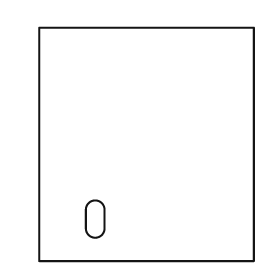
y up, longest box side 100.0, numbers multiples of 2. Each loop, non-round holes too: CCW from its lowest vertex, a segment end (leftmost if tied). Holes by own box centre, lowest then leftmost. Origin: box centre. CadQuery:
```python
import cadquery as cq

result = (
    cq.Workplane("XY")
    .moveTo(-46.0, -50.0)
    .lineTo(46.0, -50.0)
    .lineTo(46.0, 50.0)
    .lineTo(-46.0, 50.0)
    .close()
    .moveTo(-26.0, -36.0)
    .threePointArc((-22.0, -40.0), (-18.0, -36.0))
    .lineTo(-18.0, -28.0)
    .threePointArc((-22.0, -24.0), (-26.0, -28.0))
    .close()
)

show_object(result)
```